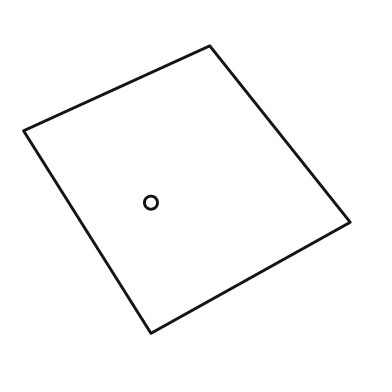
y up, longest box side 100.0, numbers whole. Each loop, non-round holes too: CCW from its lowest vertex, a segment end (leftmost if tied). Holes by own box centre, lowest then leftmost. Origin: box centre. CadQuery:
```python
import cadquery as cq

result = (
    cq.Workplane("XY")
    .moveTo(-11.0, -44.0)
    .lineTo(50.0, -10.0)
    .lineTo(7.0, 44.0)
    .lineTo(-50.0, 18.0)
    .close()
    .moveTo(-11.0, -4.0)
    .circle(2.0)
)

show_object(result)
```